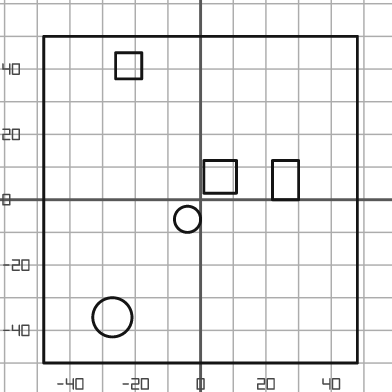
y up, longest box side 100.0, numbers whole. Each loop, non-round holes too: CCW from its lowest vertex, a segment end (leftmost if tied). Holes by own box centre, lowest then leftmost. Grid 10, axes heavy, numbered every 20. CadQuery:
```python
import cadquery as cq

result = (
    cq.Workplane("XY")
    .moveTo(-48.0, -50.0)
    .lineTo(48.0, -50.0)
    .lineTo(48.0, 50.0)
    .lineTo(-48.0, 50.0)
    .close()
    .moveTo(-27.0, -36.0)
    .circle(6.0)
    .moveTo(-4.0, -6.0)
    .circle(4.0)
    .moveTo(22.0, 0.0)
    .lineTo(30.0, 0.0)
    .lineTo(30.0, 12.0)
    .lineTo(22.0, 12.0)
    .close()
    .moveTo(1.0, 2.0)
    .lineTo(11.0, 2.0)
    .lineTo(11.0, 12.0)
    .lineTo(1.0, 12.0)
    .close()
    .moveTo(-26.0, 37.0)
    .lineTo(-18.0, 37.0)
    .lineTo(-18.0, 45.0)
    .lineTo(-26.0, 45.0)
    .close()
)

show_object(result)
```